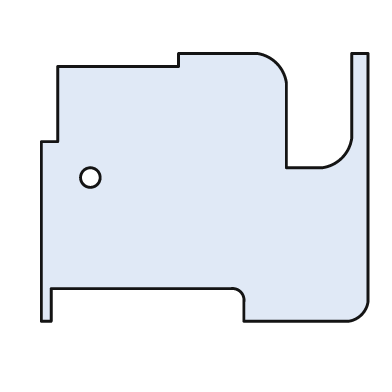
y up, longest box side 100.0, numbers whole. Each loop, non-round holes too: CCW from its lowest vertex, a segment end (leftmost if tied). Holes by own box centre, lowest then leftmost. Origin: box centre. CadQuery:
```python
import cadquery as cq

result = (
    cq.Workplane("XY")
    .moveTo(-50.0, -41.0)
    .lineTo(-47.0, -41.0)
    .lineTo(-47.0, -31.0)
    .lineTo(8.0, -31.0)
    .threePointArc((11.0, -32.0), (12.0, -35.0))
    .lineTo(12.0, -41.0)
    .lineTo(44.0, -41.0)
    .threePointArc((48.0, -39.0), (50.0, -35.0))
    .lineTo(50.0, 41.0)
    .lineTo(45.0, 41.0)
    .lineTo(45.0, 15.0)
    .threePointArc((42.0, 9.0), (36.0, 6.0))
    .lineTo(25.0, 6.0)
    .lineTo(25.0, 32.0)
    .threePointArc((22.0, 38.0), (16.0, 41.0))
    .lineTo(-8.0, 41.0)
    .lineTo(-8.0, 37.0)
    .lineTo(-45.0, 37.0)
    .lineTo(-45.0, 14.0)
    .lineTo(-50.0, 14.0)
    .close()
    .moveTo(-35.0, 3.0)
    .circle(3.0)
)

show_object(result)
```